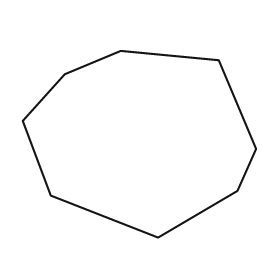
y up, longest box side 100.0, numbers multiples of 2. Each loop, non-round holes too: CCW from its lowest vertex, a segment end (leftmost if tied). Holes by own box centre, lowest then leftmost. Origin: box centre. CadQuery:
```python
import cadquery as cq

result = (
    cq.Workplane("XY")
    .moveTo(8.0, -40.0)
    .lineTo(42.0, -20.0)
    .lineTo(50.0, -2.0)
    .lineTo(34.0, 36.0)
    .lineTo(-8.0, 40.0)
    .lineTo(-32.0, 30.0)
    .lineTo(-50.0, 10.0)
    .lineTo(-38.0, -22.0)
    .close()
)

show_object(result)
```